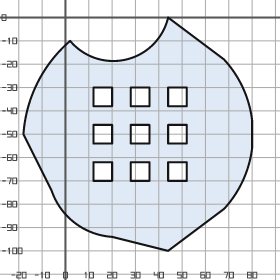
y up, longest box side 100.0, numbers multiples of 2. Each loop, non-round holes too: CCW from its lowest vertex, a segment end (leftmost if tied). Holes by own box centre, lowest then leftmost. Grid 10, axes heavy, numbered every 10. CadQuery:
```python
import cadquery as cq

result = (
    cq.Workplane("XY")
    .moveTo(44.0, -100.0)
    .lineTo(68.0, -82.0)
    .threePointArc((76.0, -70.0), (80.0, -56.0))
    .lineTo(80.0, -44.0)
    .threePointArc((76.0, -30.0), (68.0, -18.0))
    .lineTo(44.0, 0.0)
    .threePointArc((26.0, -18.0), (2.0, -10.0))
    .threePointArc((-12.0, -28.0), (-18.0, -50.0))
    .lineTo(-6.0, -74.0)
    .threePointArc((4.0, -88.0), (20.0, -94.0))
    .close()
    .moveTo(12.0, -70.0)
    .lineTo(20.0, -70.0)
    .lineTo(20.0, -62.0)
    .lineTo(12.0, -62.0)
    .close()
    .moveTo(28.0, -70.0)
    .lineTo(36.0, -70.0)
    .lineTo(36.0, -62.0)
    .lineTo(28.0, -62.0)
    .close()
    .moveTo(44.0, -70.0)
    .lineTo(52.0, -70.0)
    .lineTo(52.0, -62.0)
    .lineTo(44.0, -62.0)
    .close()
    .moveTo(12.0, -54.0)
    .lineTo(20.0, -54.0)
    .lineTo(20.0, -46.0)
    .lineTo(12.0, -46.0)
    .close()
    .moveTo(28.0, -54.0)
    .lineTo(36.0, -54.0)
    .lineTo(36.0, -46.0)
    .lineTo(28.0, -46.0)
    .close()
    .moveTo(44.0, -54.0)
    .lineTo(52.0, -54.0)
    .lineTo(52.0, -46.0)
    .lineTo(44.0, -46.0)
    .close()
    .moveTo(12.0, -38.0)
    .lineTo(20.0, -38.0)
    .lineTo(20.0, -30.0)
    .lineTo(12.0, -30.0)
    .close()
    .moveTo(28.0, -38.0)
    .lineTo(36.0, -38.0)
    .lineTo(36.0, -30.0)
    .lineTo(28.0, -30.0)
    .close()
    .moveTo(44.0, -38.0)
    .lineTo(52.0, -38.0)
    .lineTo(52.0, -30.0)
    .lineTo(44.0, -30.0)
    .close()
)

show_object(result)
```